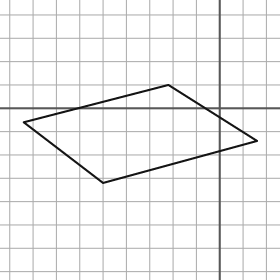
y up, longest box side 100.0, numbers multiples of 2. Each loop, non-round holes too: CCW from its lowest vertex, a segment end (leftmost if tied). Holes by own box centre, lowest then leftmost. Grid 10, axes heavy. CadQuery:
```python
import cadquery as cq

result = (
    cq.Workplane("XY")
    .moveTo(-50.0, -32.0)
    .lineTo(16.0, -14.0)
    .lineTo(-22.0, 10.0)
    .lineTo(-84.0, -6.0)
    .close()
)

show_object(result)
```